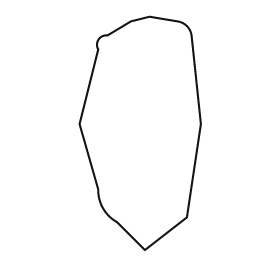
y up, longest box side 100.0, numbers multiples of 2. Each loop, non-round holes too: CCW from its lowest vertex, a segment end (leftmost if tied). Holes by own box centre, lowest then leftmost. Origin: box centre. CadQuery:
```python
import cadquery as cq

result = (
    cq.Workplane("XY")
    .moveTo(2.0, -50.0)
    .lineTo(20.0, -36.0)
    .lineTo(26.0, 4.0)
    .lineTo(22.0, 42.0)
    .threePointArc((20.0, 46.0), (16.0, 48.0))
    .lineTo(4.0, 50.0)
    .lineTo(-4.0, 48.0)
    .lineTo(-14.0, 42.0)
    .threePointArc((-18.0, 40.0), (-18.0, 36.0))
    .lineTo(-26.0, 4.0)
    .lineTo(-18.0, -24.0)
    .threePointArc((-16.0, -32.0), (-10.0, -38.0))
    .close()
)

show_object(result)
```